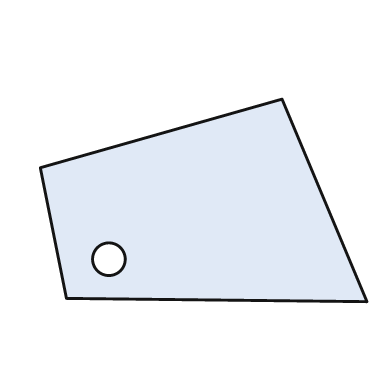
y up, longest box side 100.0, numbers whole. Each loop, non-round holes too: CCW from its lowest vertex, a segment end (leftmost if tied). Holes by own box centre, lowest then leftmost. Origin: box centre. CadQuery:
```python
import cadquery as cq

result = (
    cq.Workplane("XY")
    .moveTo(50.0, -31.0)
    .lineTo(24.0, 31.0)
    .lineTo(-50.0, 10.0)
    .lineTo(-42.0, -30.0)
    .close()
    .moveTo(-29.0, -18.0)
    .circle(5.0)
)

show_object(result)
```